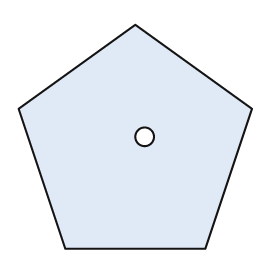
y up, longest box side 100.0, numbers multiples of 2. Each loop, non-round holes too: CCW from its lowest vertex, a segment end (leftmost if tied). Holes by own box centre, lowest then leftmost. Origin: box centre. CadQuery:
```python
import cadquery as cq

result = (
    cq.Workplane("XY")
    .moveTo(-30.0, -48.0)
    .lineTo(30.0, -48.0)
    .lineTo(50.0, 12.0)
    .lineTo(0.0, 48.0)
    .lineTo(-50.0, 12.0)
    .close()
    .moveTo(4.0, 0.0)
    .circle(4.0)
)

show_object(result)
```